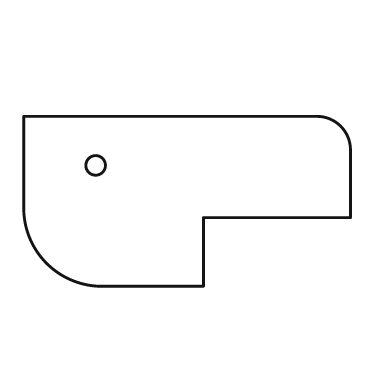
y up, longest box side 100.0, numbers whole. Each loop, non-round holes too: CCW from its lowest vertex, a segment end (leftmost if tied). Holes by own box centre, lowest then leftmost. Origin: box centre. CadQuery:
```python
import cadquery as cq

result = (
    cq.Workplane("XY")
    .moveTo(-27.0, -26.0)
    .lineTo(5.0, -26.0)
    .lineTo(5.0, -5.0)
    .lineTo(50.0, -5.0)
    .lineTo(50.0, 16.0)
    .threePointArc((47.0, 23.0), (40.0, 26.0))
    .lineTo(-50.0, 26.0)
    .lineTo(-50.0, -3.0)
    .threePointArc((-43.0, -19.0), (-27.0, -26.0))
    .close()
    .moveTo(-28.0, 11.0)
    .circle(3.0)
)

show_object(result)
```